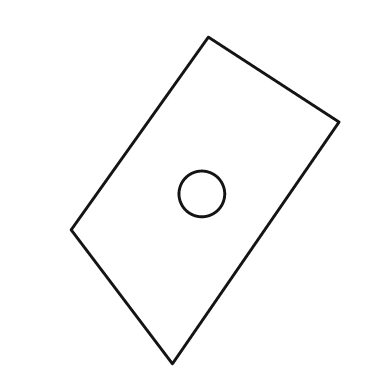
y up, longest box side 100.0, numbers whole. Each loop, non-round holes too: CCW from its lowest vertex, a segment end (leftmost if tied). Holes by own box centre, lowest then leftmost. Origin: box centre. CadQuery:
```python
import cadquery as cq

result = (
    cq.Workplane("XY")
    .moveTo(-10.0, -50.0)
    .lineTo(41.0, 24.0)
    .lineTo(1.0, 50.0)
    .lineTo(-41.0, -9.0)
    .close()
    .moveTo(-1.0, 2.0)
    .circle(7.0)
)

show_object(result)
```